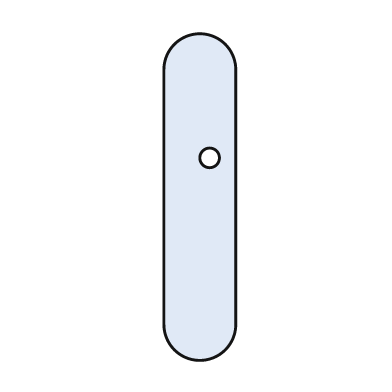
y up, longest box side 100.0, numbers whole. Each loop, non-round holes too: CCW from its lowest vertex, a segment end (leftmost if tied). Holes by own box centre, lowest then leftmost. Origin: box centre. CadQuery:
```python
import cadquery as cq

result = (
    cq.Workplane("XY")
    .moveTo(-11.0, -39.0)
    .threePointArc((0.0, -50.0), (11.0, -39.0))
    .lineTo(11.0, 39.0)
    .threePointArc((0.0, 50.0), (-11.0, 39.0))
    .close()
    .moveTo(3.0, 12.0)
    .circle(3.0)
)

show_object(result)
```